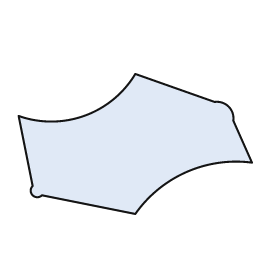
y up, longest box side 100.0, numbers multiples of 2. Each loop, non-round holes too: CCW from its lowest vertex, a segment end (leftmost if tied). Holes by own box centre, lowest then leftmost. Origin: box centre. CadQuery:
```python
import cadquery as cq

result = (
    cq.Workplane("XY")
    .moveTo(0.0, -30.0)
    .threePointArc((22.0, -12.0), (50.0, -8.0))
    .lineTo(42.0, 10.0)
    .threePointArc((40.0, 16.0), (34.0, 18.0))
    .lineTo(0.0, 30.0)
    .threePointArc((-22.0, 12.0), (-50.0, 12.0))
    .lineTo(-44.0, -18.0)
    .threePointArc((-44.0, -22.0), (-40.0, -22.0))
    .close()
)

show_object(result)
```